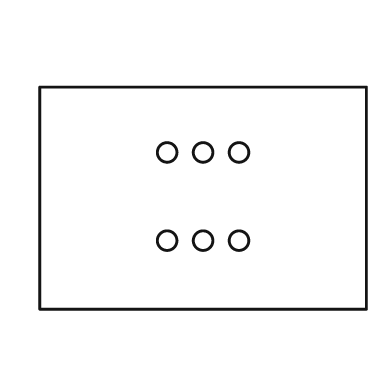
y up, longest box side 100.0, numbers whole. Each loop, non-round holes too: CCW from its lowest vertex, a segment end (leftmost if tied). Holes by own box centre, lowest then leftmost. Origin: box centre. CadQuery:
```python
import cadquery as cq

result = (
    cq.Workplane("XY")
    .moveTo(-50.0, -34.0)
    .lineTo(50.0, -34.0)
    .lineTo(50.0, 34.0)
    .lineTo(-50.0, 34.0)
    .close()
    .moveTo(-11.0, -13.0)
    .circle(3.0)
    .moveTo(0.0, -13.0)
    .circle(3.0)
    .moveTo(11.0, -13.0)
    .circle(3.0)
    .moveTo(-11.0, 14.0)
    .circle(3.0)
    .moveTo(0.0, 14.0)
    .circle(3.0)
    .moveTo(11.0, 14.0)
    .circle(3.0)
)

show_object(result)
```